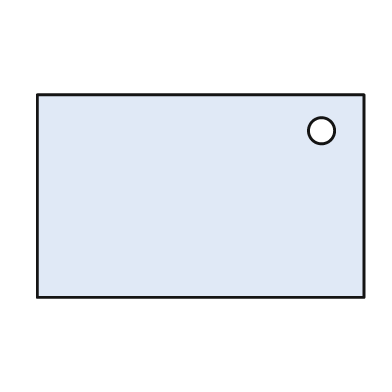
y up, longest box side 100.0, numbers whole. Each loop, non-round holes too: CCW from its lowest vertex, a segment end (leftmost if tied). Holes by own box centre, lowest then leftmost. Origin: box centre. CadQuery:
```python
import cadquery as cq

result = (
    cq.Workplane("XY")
    .moveTo(-50.0, -31.0)
    .lineTo(50.0, -31.0)
    .lineTo(50.0, 31.0)
    .lineTo(-50.0, 31.0)
    .close()
    .moveTo(37.0, 20.0)
    .circle(4.0)
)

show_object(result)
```